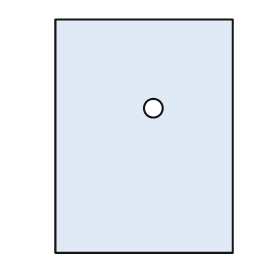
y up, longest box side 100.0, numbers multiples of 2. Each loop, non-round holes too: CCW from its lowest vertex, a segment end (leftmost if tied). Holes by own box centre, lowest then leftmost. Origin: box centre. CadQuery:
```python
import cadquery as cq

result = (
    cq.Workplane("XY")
    .moveTo(-38.0, -50.0)
    .lineTo(38.0, -50.0)
    .lineTo(38.0, 50.0)
    .lineTo(-38.0, 50.0)
    .close()
    .moveTo(4.0, 12.0)
    .circle(4.0)
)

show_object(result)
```